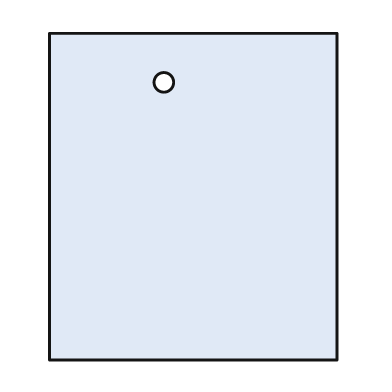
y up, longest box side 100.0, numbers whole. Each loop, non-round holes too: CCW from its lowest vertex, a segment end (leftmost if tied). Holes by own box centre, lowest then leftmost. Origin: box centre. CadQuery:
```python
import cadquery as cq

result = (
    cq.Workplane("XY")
    .moveTo(-44.0, -50.0)
    .lineTo(44.0, -50.0)
    .lineTo(44.0, 50.0)
    .lineTo(-44.0, 50.0)
    .close()
    .moveTo(-9.0, 35.0)
    .circle(3.0)
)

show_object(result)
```